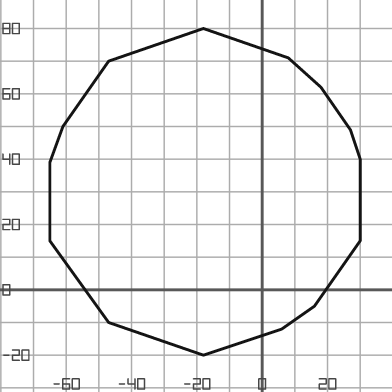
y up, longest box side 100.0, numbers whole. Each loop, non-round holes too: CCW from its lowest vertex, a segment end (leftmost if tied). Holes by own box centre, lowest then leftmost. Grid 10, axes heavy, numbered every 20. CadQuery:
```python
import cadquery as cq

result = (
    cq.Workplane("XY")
    .moveTo(-18.0, -20.0)
    .lineTo(6.0, -12.0)
    .lineTo(16.0, -5.0)
    .lineTo(30.0, 15.0)
    .lineTo(30.0, 40.0)
    .lineTo(27.0, 49.0)
    .lineTo(18.0, 62.0)
    .lineTo(8.0, 71.0)
    .lineTo(-18.0, 80.0)
    .lineTo(-47.0, 70.0)
    .lineTo(-61.0, 50.0)
    .lineTo(-65.0, 39.0)
    .lineTo(-65.0, 15.0)
    .lineTo(-47.0, -10.0)
    .close()
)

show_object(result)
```